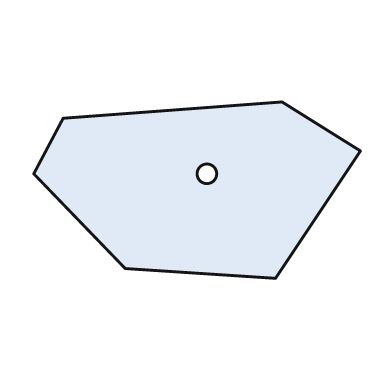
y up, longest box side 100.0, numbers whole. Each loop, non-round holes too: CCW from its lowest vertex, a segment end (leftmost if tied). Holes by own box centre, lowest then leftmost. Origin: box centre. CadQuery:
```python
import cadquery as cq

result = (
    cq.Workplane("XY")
    .moveTo(24.0, -27.0)
    .lineTo(50.0, 12.0)
    .lineTo(26.0, 27.0)
    .lineTo(-41.0, 22.0)
    .lineTo(-50.0, 5.0)
    .lineTo(-22.0, -24.0)
    .close()
    .moveTo(3.0, 5.0)
    .circle(3.0)
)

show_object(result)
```